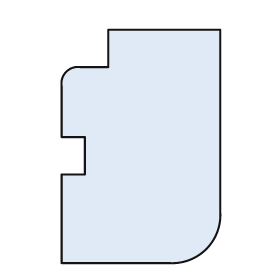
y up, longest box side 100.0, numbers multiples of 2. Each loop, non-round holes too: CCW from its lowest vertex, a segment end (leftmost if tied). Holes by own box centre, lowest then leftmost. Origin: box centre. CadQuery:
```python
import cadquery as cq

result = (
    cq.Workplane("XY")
    .moveTo(-34.0, -50.0)
    .lineTo(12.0, -50.0)
    .threePointArc((28.0, -44.0), (34.0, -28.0))
    .lineTo(34.0, 50.0)
    .lineTo(-14.0, 50.0)
    .lineTo(-14.0, 34.0)
    .lineTo(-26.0, 34.0)
    .threePointArc((-32.0, 32.0), (-34.0, 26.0))
    .lineTo(-34.0, 4.0)
    .lineTo(-24.0, 4.0)
    .lineTo(-24.0, -12.0)
    .lineTo(-34.0, -12.0)
    .close()
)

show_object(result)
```